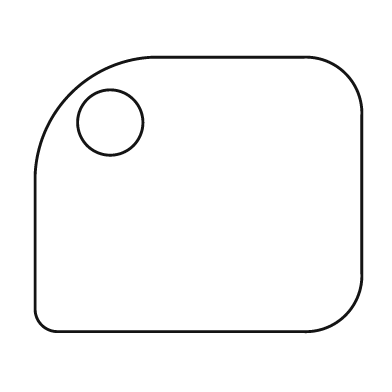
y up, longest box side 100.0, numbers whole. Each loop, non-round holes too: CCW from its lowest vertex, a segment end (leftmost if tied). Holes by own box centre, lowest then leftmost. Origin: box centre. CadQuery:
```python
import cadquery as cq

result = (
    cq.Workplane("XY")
    .moveTo(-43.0, -42.0)
    .lineTo(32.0, -42.0)
    .threePointArc((45.0, -37.0), (50.0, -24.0))
    .lineTo(50.0, 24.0)
    .threePointArc((45.0, 37.0), (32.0, 42.0))
    .lineTo(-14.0, 42.0)
    .threePointArc((-39.0, 31.0), (-50.0, 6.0))
    .lineTo(-50.0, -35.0)
    .threePointArc((-48.0, -40.0), (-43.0, -42.0))
    .close()
    .moveTo(-27.0, 22.0)
    .circle(10.0)
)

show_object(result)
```